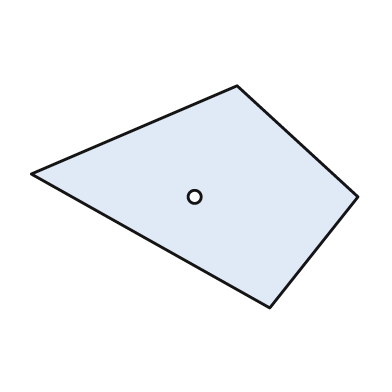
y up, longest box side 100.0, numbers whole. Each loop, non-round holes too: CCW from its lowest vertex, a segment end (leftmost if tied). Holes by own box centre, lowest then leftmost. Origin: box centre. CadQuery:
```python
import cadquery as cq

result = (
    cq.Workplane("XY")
    .moveTo(23.0, -34.0)
    .lineTo(50.0, 0.0)
    .lineTo(13.0, 34.0)
    .lineTo(-50.0, 7.0)
    .close()
    .moveTo(0.0, 0.0)
    .circle(2.0)
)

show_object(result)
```